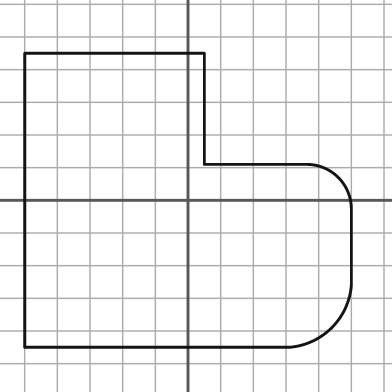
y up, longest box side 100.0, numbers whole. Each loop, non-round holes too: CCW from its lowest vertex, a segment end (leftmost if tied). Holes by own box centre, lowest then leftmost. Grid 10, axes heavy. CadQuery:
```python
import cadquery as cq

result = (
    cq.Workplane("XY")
    .moveTo(-50.0, -45.0)
    .lineTo(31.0, -45.0)
    .threePointArc((44.0, -39.0), (50.0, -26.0))
    .lineTo(50.0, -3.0)
    .threePointArc((46.0, 7.0), (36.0, 11.0))
    .lineTo(5.0, 11.0)
    .lineTo(5.0, 45.0)
    .lineTo(-50.0, 45.0)
    .close()
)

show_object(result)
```